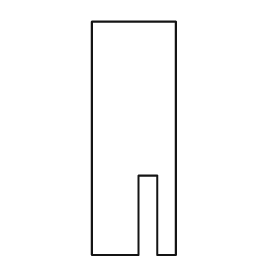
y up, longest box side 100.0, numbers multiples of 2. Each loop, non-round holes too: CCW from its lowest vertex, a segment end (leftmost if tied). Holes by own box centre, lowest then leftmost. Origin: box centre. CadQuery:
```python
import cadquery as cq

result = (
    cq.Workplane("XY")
    .moveTo(-18.0, -50.0)
    .lineTo(2.0, -50.0)
    .lineTo(2.0, -16.0)
    .lineTo(10.0, -16.0)
    .lineTo(10.0, -50.0)
    .lineTo(18.0, -50.0)
    .lineTo(18.0, 50.0)
    .lineTo(-18.0, 50.0)
    .close()
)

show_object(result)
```